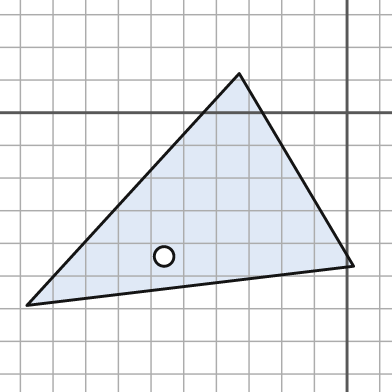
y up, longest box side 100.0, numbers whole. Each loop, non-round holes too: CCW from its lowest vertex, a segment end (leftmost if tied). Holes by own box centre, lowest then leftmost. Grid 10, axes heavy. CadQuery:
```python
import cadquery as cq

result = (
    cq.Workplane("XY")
    .moveTo(-98.0, -59.0)
    .lineTo(2.0, -47.0)
    .lineTo(-33.0, 12.0)
    .close()
    .moveTo(-56.0, -44.0)
    .circle(3.0)
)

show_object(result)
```